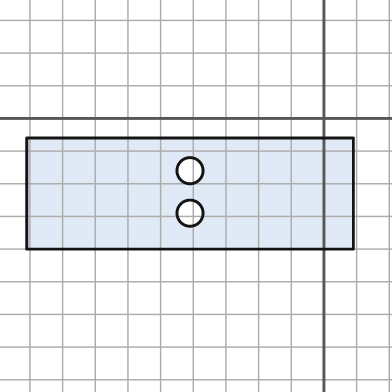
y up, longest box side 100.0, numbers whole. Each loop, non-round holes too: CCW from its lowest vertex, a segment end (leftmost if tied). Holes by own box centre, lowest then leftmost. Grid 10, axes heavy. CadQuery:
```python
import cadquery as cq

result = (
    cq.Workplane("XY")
    .moveTo(-91.0, -40.0)
    .lineTo(9.0, -40.0)
    .lineTo(9.0, -6.0)
    .lineTo(-91.0, -6.0)
    .close()
    .moveTo(-41.0, -29.0)
    .circle(4.0)
    .moveTo(-41.0, -16.0)
    .circle(4.0)
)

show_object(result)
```